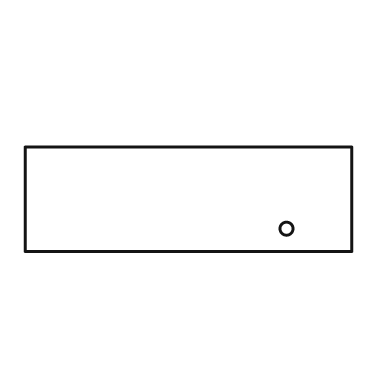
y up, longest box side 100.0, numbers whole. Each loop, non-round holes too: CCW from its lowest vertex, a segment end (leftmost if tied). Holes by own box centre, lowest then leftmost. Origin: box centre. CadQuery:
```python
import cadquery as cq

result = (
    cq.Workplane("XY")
    .moveTo(-50.0, -16.0)
    .lineTo(50.0, -16.0)
    .lineTo(50.0, 16.0)
    .lineTo(-50.0, 16.0)
    .close()
    .moveTo(30.0, -9.0)
    .circle(2.0)
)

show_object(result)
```